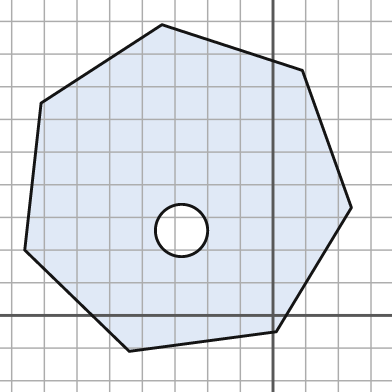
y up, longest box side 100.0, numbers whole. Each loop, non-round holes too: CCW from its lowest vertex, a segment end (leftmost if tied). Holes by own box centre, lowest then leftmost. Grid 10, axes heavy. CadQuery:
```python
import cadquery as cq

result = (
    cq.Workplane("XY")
    .moveTo(-44.0, -11.0)
    .lineTo(1.0, -5.0)
    .lineTo(24.0, 33.0)
    .lineTo(9.0, 75.0)
    .lineTo(-34.0, 89.0)
    .lineTo(-71.0, 65.0)
    .lineTo(-76.0, 20.0)
    .close()
    .moveTo(-28.0, 26.0)
    .circle(8.0)
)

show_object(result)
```